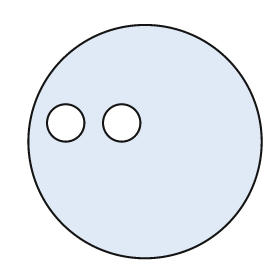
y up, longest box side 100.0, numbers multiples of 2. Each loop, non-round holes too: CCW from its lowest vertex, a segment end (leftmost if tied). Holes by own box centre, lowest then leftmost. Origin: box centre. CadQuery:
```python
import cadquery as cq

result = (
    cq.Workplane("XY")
    .moveTo(0.0, 0.0)
    .circle(50.0)
    .moveTo(-34.0, 8.0)
    .circle(8.0)
    .moveTo(-10.0, 8.0)
    .circle(8.0)
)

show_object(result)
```